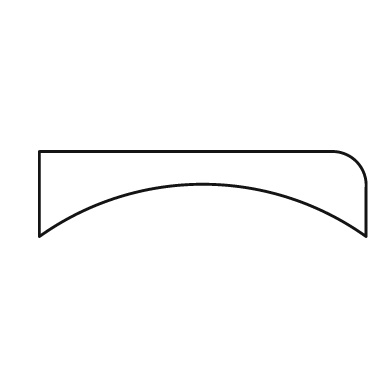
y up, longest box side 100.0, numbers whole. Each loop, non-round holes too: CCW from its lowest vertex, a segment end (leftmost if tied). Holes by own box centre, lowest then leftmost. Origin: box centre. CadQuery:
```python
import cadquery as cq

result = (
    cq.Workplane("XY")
    .moveTo(-50.0, -13.0)
    .threePointArc((0.0, 3.0), (50.0, -13.0))
    .lineTo(50.0, 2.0)
    .threePointArc((47.0, 10.0), (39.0, 13.0))
    .lineTo(-50.0, 13.0)
    .close()
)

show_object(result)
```